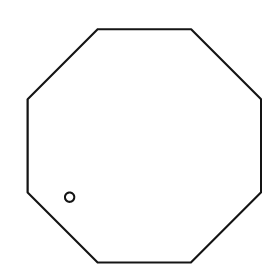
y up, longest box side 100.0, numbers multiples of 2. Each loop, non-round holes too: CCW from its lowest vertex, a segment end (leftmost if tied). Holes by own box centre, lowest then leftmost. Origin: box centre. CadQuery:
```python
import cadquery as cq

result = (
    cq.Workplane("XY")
    .moveTo(-20.0, -50.0)
    .lineTo(20.0, -50.0)
    .lineTo(50.0, -20.0)
    .lineTo(50.0, 20.0)
    .lineTo(20.0, 50.0)
    .lineTo(-20.0, 50.0)
    .lineTo(-50.0, 20.0)
    .lineTo(-50.0, -20.0)
    .close()
    .moveTo(-32.0, -22.0)
    .circle(2.0)
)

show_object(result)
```